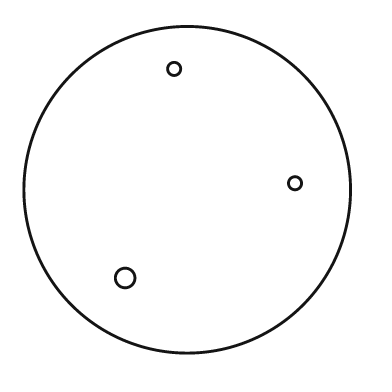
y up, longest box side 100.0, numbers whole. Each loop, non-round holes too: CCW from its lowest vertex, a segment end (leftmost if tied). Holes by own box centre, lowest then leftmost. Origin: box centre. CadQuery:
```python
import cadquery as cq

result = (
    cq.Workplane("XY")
    .moveTo(0.0, 0.0)
    .circle(50.0)
    .moveTo(-19.0, -27.0)
    .circle(3.0)
    .moveTo(33.0, 2.0)
    .circle(2.0)
    .moveTo(-4.0, 37.0)
    .circle(2.0)
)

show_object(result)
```